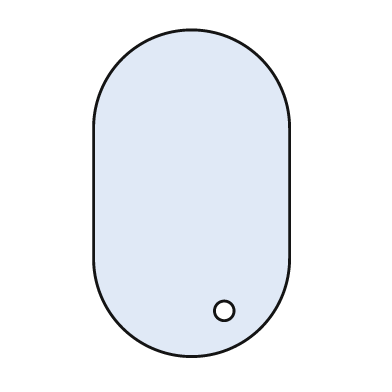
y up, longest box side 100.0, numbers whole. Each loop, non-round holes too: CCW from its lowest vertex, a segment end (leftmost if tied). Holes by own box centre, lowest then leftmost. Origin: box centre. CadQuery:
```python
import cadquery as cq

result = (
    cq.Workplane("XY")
    .moveTo(-30.0, -20.0)
    .threePointArc((0.0, -50.0), (30.0, -20.0))
    .lineTo(30.0, 20.0)
    .threePointArc((0.0, 50.0), (-30.0, 20.0))
    .close()
    .moveTo(10.0, -36.0)
    .circle(3.0)
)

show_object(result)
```